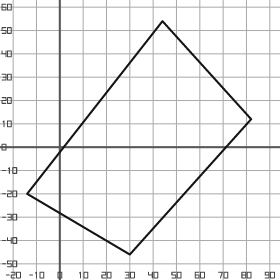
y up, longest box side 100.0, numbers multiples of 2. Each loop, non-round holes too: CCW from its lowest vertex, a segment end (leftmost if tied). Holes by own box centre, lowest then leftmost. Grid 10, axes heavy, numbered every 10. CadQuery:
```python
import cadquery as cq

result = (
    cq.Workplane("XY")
    .moveTo(30.0, -46.0)
    .lineTo(82.0, 12.0)
    .lineTo(44.0, 54.0)
    .lineTo(-14.0, -20.0)
    .close()
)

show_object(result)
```